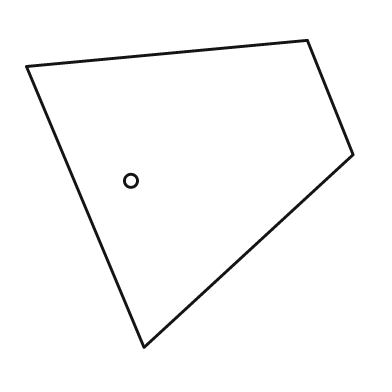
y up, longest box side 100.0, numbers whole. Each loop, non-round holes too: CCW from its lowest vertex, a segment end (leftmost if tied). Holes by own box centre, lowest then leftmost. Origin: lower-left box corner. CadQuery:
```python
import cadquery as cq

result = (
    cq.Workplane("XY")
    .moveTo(36.0, 0.0)
    .lineTo(100.0, 59.0)
    .lineTo(86.0, 94.0)
    .lineTo(0.0, 86.0)
    .close()
    .moveTo(32.0, 51.0)
    .circle(2.0)
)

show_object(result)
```